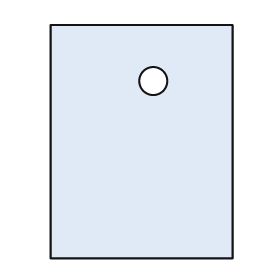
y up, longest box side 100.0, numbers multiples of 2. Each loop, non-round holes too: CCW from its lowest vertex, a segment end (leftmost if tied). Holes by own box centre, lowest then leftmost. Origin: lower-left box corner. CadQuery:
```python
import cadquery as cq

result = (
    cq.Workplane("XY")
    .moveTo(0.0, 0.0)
    .lineTo(78.0, 0.0)
    .lineTo(78.0, 100.0)
    .lineTo(0.0, 100.0)
    .close()
    .moveTo(44.0, 76.0)
    .circle(6.0)
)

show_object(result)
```